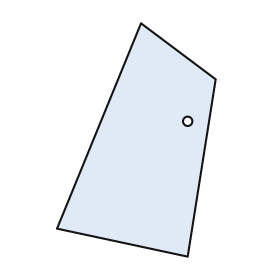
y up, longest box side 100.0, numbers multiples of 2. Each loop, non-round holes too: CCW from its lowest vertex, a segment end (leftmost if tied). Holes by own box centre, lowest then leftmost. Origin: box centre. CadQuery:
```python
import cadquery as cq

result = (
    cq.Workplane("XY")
    .moveTo(22.0, -50.0)
    .lineTo(34.0, 26.0)
    .lineTo(2.0, 50.0)
    .lineTo(-34.0, -38.0)
    .close()
    .moveTo(22.0, 8.0)
    .circle(2.0)
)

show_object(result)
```